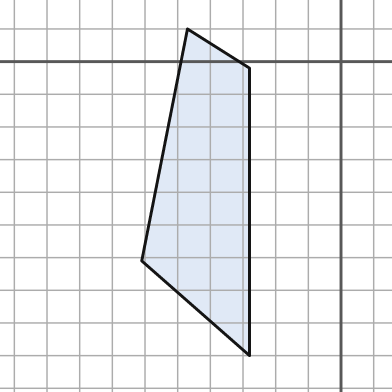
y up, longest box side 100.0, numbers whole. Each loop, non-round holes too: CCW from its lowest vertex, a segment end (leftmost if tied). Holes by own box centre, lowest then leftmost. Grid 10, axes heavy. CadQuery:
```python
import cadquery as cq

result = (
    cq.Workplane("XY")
    .moveTo(-28.0, -90.0)
    .lineTo(-28.0, -2.0)
    .lineTo(-47.0, 10.0)
    .lineTo(-61.0, -61.0)
    .close()
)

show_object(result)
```